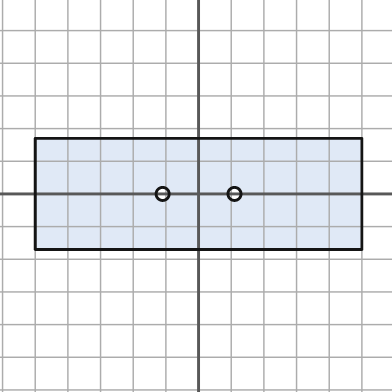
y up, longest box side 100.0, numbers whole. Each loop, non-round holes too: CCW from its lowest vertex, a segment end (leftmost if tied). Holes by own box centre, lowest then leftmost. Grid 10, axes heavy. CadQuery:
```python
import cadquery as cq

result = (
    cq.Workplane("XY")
    .moveTo(-50.0, -17.0)
    .lineTo(50.0, -17.0)
    .lineTo(50.0, 17.0)
    .lineTo(-50.0, 17.0)
    .close()
    .moveTo(-11.0, 0.0)
    .circle(2.0)
    .moveTo(11.0, 0.0)
    .circle(2.0)
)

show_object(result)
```